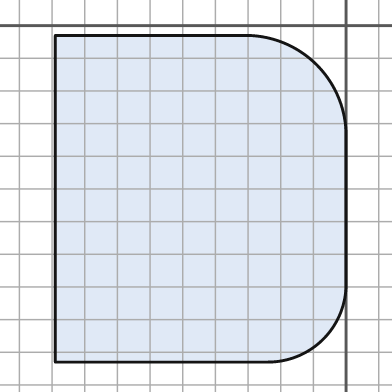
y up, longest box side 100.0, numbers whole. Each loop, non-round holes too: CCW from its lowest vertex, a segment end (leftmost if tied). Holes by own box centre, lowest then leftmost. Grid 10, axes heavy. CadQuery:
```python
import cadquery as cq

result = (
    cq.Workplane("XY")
    .moveTo(-89.0, -103.0)
    .lineTo(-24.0, -103.0)
    .threePointArc((-7.0, -96.0), (0.0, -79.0))
    .lineTo(0.0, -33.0)
    .threePointArc((-9.0, -12.0), (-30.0, -3.0))
    .lineTo(-89.0, -3.0)
    .close()
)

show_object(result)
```